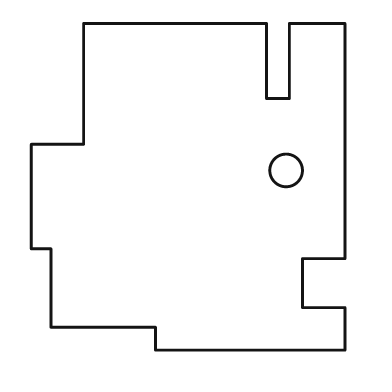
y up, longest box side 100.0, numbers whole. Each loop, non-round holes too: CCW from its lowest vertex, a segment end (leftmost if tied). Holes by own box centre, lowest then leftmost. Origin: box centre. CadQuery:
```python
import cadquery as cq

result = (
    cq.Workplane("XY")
    .moveTo(-10.0, -50.0)
    .lineTo(48.0, -50.0)
    .lineTo(48.0, -37.0)
    .lineTo(35.0, -37.0)
    .lineTo(35.0, -22.0)
    .lineTo(48.0, -22.0)
    .lineTo(48.0, 50.0)
    .lineTo(31.0, 50.0)
    .lineTo(31.0, 27.0)
    .lineTo(24.0, 27.0)
    .lineTo(24.0, 50.0)
    .lineTo(-32.0, 50.0)
    .lineTo(-32.0, 13.0)
    .lineTo(-48.0, 13.0)
    .lineTo(-48.0, -19.0)
    .lineTo(-42.0, -19.0)
    .lineTo(-42.0, -43.0)
    .lineTo(-10.0, -43.0)
    .close()
    .moveTo(30.0, 5.0)
    .circle(5.0)
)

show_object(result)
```